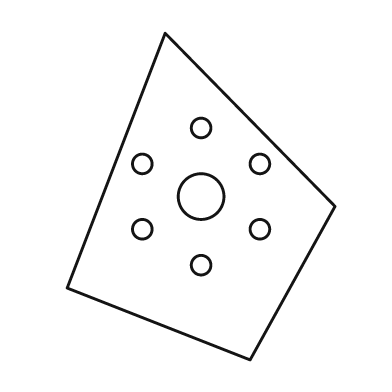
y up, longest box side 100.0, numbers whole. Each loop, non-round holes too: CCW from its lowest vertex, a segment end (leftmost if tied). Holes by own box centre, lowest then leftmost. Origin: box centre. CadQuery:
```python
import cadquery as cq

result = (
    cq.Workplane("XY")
    .moveTo(15.0, -50.0)
    .lineTo(41.0, -3.0)
    .lineTo(-11.0, 50.0)
    .lineTo(-41.0, -28.0)
    .close()
    .moveTo(0.0, -21.0)
    .circle(3.0)
    .moveTo(-18.0, -10.0)
    .circle(3.0)
    .moveTo(18.0, -10.0)
    .circle(3.0)
    .moveTo(0.0, 0.0)
    .circle(7.0)
    .moveTo(-18.0, 10.0)
    .circle(3.0)
    .moveTo(18.0, 10.0)
    .circle(3.0)
    .moveTo(0.0, 21.0)
    .circle(3.0)
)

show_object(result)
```